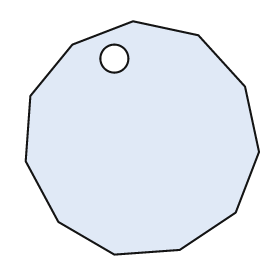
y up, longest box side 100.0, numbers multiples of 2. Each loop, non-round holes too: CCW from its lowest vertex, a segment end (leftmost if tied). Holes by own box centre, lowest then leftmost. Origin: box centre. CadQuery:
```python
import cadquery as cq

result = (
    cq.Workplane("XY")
    .moveTo(-12.0, -50.0)
    .lineTo(16.0, -48.0)
    .lineTo(40.0, -32.0)
    .lineTo(50.0, -6.0)
    .lineTo(44.0, 22.0)
    .lineTo(24.0, 44.0)
    .lineTo(-4.0, 50.0)
    .lineTo(-30.0, 40.0)
    .lineTo(-48.0, 18.0)
    .lineTo(-50.0, -10.0)
    .lineTo(-36.0, -36.0)
    .close()
    .moveTo(-12.0, 34.0)
    .circle(6.0)
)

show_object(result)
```